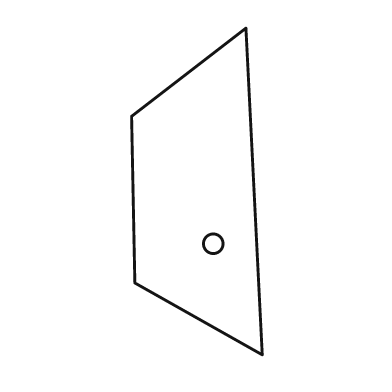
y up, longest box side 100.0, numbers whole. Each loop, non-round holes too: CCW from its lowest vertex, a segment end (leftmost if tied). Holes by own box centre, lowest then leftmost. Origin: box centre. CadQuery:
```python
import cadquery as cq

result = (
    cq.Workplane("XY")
    .moveTo(20.0, -50.0)
    .lineTo(15.0, 50.0)
    .lineTo(-20.0, 23.0)
    .lineTo(-19.0, -28.0)
    .close()
    .moveTo(5.0, -16.0)
    .circle(3.0)
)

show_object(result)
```